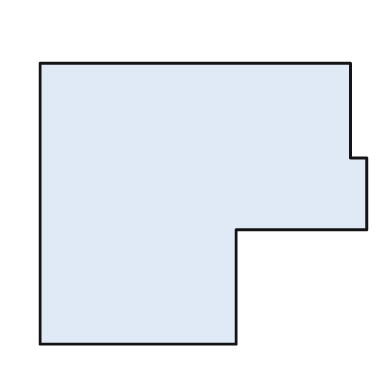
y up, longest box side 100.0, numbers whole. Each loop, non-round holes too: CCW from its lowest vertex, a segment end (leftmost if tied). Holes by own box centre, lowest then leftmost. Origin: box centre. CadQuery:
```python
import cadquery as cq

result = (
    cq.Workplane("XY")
    .moveTo(-50.0, -43.0)
    .lineTo(10.0, -43.0)
    .lineTo(10.0, -8.0)
    .lineTo(50.0, -8.0)
    .lineTo(50.0, 14.0)
    .lineTo(45.0, 14.0)
    .lineTo(45.0, 43.0)
    .lineTo(-50.0, 43.0)
    .close()
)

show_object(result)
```